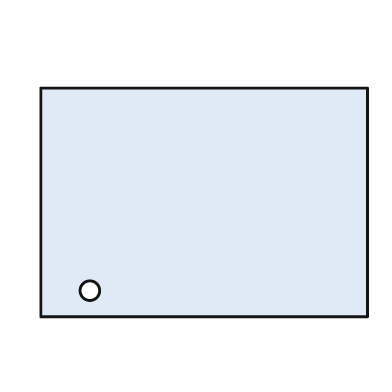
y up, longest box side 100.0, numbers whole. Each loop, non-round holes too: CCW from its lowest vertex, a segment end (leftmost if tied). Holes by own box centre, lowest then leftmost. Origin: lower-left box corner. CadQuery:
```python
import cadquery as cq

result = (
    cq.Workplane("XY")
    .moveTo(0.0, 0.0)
    .lineTo(100.0, 0.0)
    .lineTo(100.0, 70.0)
    .lineTo(0.0, 70.0)
    .close()
    .moveTo(15.0, 8.0)
    .circle(3.0)
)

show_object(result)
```